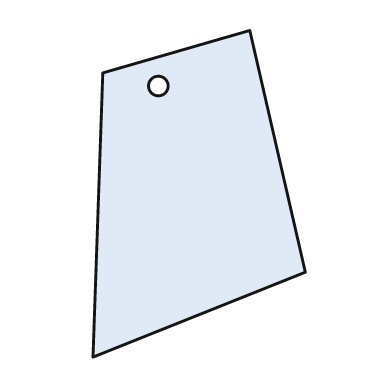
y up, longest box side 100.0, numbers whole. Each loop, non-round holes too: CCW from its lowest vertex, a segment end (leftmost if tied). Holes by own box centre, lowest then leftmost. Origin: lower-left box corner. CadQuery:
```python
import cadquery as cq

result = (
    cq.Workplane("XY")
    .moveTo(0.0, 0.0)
    .lineTo(65.0, 26.0)
    .lineTo(48.0, 100.0)
    .lineTo(3.0, 87.0)
    .close()
    .moveTo(20.0, 83.0)
    .circle(3.0)
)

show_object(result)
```